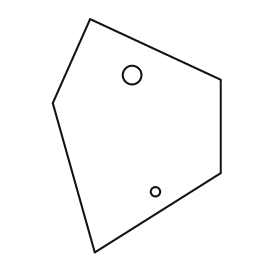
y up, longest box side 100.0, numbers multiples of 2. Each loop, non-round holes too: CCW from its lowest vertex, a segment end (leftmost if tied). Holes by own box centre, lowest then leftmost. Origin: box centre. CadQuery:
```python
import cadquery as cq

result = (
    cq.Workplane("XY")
    .moveTo(-18.0, -50.0)
    .lineTo(36.0, -16.0)
    .lineTo(36.0, 24.0)
    .lineTo(-20.0, 50.0)
    .lineTo(-36.0, 14.0)
    .close()
    .moveTo(8.0, -24.0)
    .circle(2.0)
    .moveTo(-2.0, 26.0)
    .circle(4.0)
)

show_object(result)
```